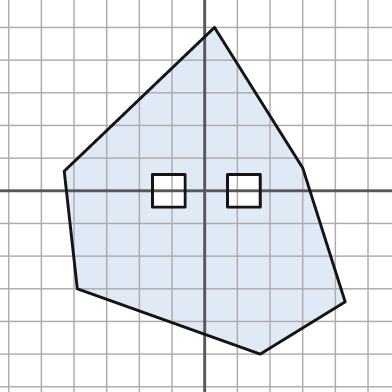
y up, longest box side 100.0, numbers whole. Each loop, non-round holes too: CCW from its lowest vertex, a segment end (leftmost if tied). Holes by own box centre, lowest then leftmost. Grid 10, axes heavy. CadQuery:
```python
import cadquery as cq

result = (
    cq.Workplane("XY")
    .moveTo(17.0, -50.0)
    .lineTo(43.0, -34.0)
    .lineTo(30.0, 7.0)
    .lineTo(3.0, 50.0)
    .lineTo(-43.0, 6.0)
    .lineTo(-39.0, -30.0)
    .close()
    .moveTo(-16.0, -5.0)
    .lineTo(-6.0, -5.0)
    .lineTo(-6.0, 5.0)
    .lineTo(-16.0, 5.0)
    .close()
    .moveTo(7.0, -5.0)
    .lineTo(17.0, -5.0)
    .lineTo(17.0, 5.0)
    .lineTo(7.0, 5.0)
    .close()
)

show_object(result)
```